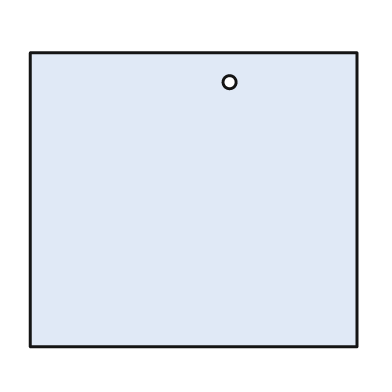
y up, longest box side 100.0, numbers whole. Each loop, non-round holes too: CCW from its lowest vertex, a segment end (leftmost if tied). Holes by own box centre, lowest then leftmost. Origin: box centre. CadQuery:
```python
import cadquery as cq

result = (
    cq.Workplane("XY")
    .moveTo(-50.0, -45.0)
    .lineTo(50.0, -45.0)
    .lineTo(50.0, 45.0)
    .lineTo(-50.0, 45.0)
    .close()
    .moveTo(11.0, 36.0)
    .circle(2.0)
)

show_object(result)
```